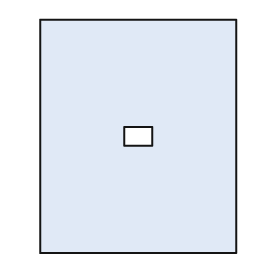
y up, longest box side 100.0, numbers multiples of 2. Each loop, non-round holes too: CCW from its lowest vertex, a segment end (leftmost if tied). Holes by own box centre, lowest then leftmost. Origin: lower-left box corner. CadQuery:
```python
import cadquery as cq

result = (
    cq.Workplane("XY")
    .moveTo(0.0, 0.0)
    .lineTo(84.0, 0.0)
    .lineTo(84.0, 100.0)
    .lineTo(0.0, 100.0)
    .close()
    .moveTo(36.0, 46.0)
    .lineTo(48.0, 46.0)
    .lineTo(48.0, 54.0)
    .lineTo(36.0, 54.0)
    .close()
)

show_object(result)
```